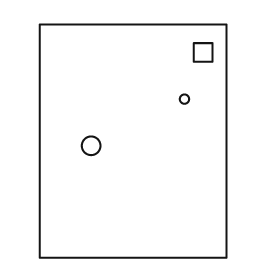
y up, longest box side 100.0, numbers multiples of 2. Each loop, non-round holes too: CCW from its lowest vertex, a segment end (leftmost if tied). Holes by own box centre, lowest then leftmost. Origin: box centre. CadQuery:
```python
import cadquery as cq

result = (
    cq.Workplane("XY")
    .moveTo(-40.0, -50.0)
    .lineTo(40.0, -50.0)
    .lineTo(40.0, 50.0)
    .lineTo(-40.0, 50.0)
    .close()
    .moveTo(-18.0, -2.0)
    .circle(4.0)
    .moveTo(22.0, 18.0)
    .circle(2.0)
    .moveTo(26.0, 34.0)
    .lineTo(34.0, 34.0)
    .lineTo(34.0, 42.0)
    .lineTo(26.0, 42.0)
    .close()
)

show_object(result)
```